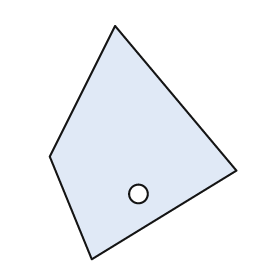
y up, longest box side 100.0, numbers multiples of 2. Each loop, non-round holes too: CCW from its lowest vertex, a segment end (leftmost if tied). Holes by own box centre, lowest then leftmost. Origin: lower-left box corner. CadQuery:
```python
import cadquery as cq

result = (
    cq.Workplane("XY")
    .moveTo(18.0, 0.0)
    .lineTo(80.0, 38.0)
    .lineTo(28.0, 100.0)
    .lineTo(0.0, 44.0)
    .close()
    .moveTo(38.0, 28.0)
    .circle(4.0)
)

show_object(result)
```